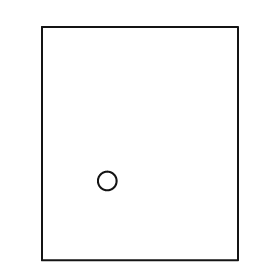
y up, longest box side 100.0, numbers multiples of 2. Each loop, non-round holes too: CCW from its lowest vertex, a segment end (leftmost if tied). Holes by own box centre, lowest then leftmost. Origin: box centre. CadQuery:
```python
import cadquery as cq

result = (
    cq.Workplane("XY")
    .moveTo(-42.0, -50.0)
    .lineTo(42.0, -50.0)
    .lineTo(42.0, 50.0)
    .lineTo(-42.0, 50.0)
    .close()
    .moveTo(-14.0, -16.0)
    .circle(4.0)
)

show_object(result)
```